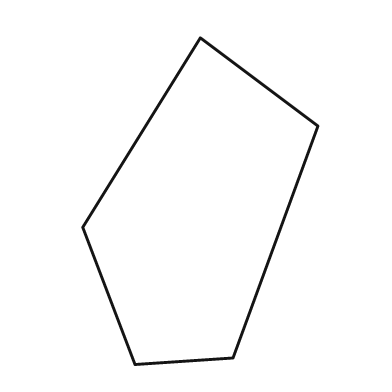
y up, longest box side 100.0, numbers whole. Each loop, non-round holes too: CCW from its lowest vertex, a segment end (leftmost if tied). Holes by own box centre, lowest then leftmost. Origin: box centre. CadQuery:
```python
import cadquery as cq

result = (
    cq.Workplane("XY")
    .moveTo(-20.0, -50.0)
    .lineTo(10.0, -48.0)
    .lineTo(36.0, 23.0)
    .lineTo(0.0, 50.0)
    .lineTo(-36.0, -8.0)
    .close()
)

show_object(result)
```